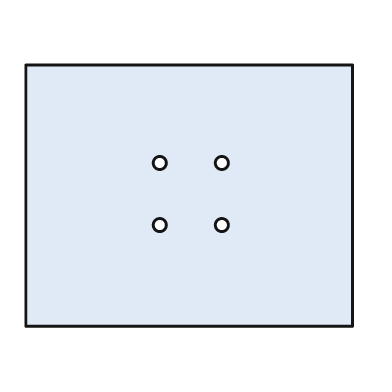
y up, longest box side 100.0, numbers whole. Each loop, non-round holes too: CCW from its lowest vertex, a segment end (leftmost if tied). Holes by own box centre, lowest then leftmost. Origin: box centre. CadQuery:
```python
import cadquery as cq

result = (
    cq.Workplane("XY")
    .moveTo(-50.0, -40.0)
    .lineTo(50.0, -40.0)
    .lineTo(50.0, 40.0)
    .lineTo(-50.0, 40.0)
    .close()
    .moveTo(-9.0, -9.0)
    .circle(2.0)
    .moveTo(10.0, -9.0)
    .circle(2.0)
    .moveTo(-9.0, 10.0)
    .circle(2.0)
    .moveTo(10.0, 10.0)
    .circle(2.0)
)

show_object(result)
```